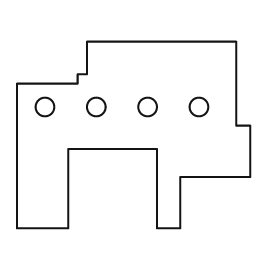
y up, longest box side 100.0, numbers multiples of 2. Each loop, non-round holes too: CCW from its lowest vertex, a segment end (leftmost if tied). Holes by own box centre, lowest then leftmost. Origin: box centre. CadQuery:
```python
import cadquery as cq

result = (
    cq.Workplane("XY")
    .moveTo(-50.0, -40.0)
    .lineTo(-28.0, -40.0)
    .lineTo(-28.0, -6.0)
    .lineTo(10.0, -6.0)
    .lineTo(10.0, -40.0)
    .lineTo(20.0, -40.0)
    .lineTo(20.0, -18.0)
    .lineTo(50.0, -18.0)
    .lineTo(50.0, 4.0)
    .lineTo(44.0, 4.0)
    .lineTo(44.0, 40.0)
    .lineTo(-20.0, 40.0)
    .lineTo(-20.0, 26.0)
    .lineTo(-24.0, 26.0)
    .lineTo(-24.0, 22.0)
    .lineTo(-50.0, 22.0)
    .close()
    .moveTo(-38.0, 12.0)
    .circle(4.0)
    .moveTo(-16.0, 12.0)
    .circle(4.0)
    .moveTo(6.0, 12.0)
    .circle(4.0)
    .moveTo(28.0, 12.0)
    .circle(4.0)
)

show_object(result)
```